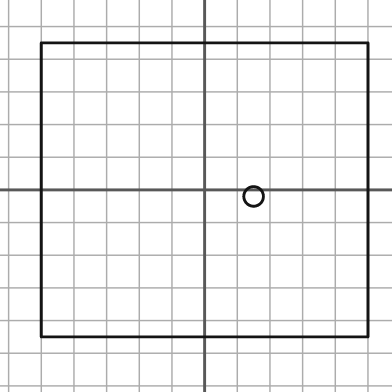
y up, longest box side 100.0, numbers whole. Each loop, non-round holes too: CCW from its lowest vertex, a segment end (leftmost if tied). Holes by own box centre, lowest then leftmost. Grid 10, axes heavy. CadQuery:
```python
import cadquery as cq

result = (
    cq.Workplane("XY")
    .moveTo(-50.0, -45.0)
    .lineTo(50.0, -45.0)
    .lineTo(50.0, 45.0)
    .lineTo(-50.0, 45.0)
    .close()
    .moveTo(15.0, -2.0)
    .circle(3.0)
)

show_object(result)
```